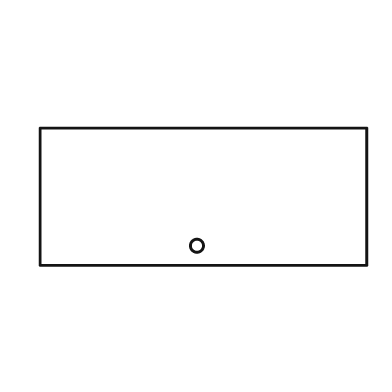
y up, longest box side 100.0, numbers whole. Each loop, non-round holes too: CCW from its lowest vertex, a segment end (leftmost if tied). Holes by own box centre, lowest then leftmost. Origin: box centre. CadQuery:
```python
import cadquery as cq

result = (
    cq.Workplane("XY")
    .moveTo(-50.0, -21.0)
    .lineTo(50.0, -21.0)
    .lineTo(50.0, 21.0)
    .lineTo(-50.0, 21.0)
    .close()
    .moveTo(-2.0, -15.0)
    .circle(2.0)
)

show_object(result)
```